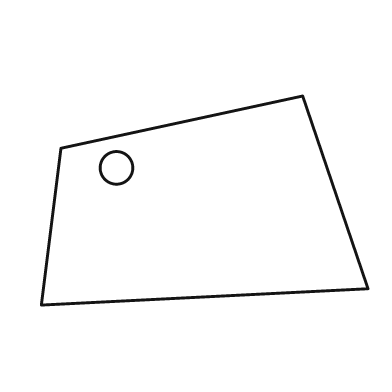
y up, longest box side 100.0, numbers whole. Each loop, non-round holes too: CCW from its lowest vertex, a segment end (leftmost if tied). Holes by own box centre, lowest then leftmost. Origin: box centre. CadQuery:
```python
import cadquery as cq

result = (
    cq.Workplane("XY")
    .moveTo(-50.0, -32.0)
    .lineTo(50.0, -27.0)
    .lineTo(30.0, 32.0)
    .lineTo(-44.0, 16.0)
    .close()
    .moveTo(-27.0, 10.0)
    .circle(5.0)
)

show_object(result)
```